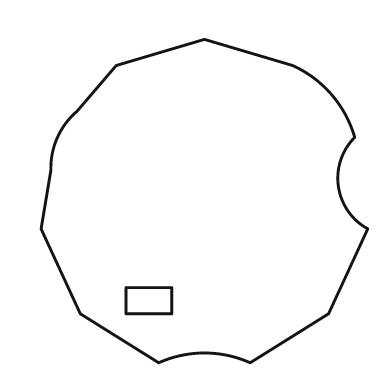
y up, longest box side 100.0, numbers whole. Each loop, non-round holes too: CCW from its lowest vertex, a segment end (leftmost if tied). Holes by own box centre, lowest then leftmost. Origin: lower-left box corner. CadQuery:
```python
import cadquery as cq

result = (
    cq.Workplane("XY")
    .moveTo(36.0, 0.0)
    .threePointArc((50.0, 3.0), (64.0, 0.0))
    .lineTo(88.0, 15.0)
    .lineTo(100.0, 41.0)
    .threePointArc((91.0, 54.0), (96.0, 69.0))
    .threePointArc((89.0, 82.0), (77.0, 91.0))
    .lineTo(50.0, 99.0)
    .lineTo(23.0, 91.0)
    .lineTo(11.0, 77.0)
    .threePointArc((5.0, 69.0), (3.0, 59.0))
    .lineTo(0.0, 41.0)
    .lineTo(12.0, 15.0)
    .close()
    .moveTo(26.0, 15.0)
    .lineTo(40.0, 15.0)
    .lineTo(40.0, 23.0)
    .lineTo(26.0, 23.0)
    .close()
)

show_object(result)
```